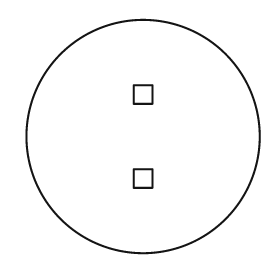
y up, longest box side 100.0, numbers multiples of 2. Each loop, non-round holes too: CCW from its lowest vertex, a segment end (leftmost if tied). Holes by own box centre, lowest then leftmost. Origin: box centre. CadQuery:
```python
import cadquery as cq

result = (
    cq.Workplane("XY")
    .moveTo(0.0, 0.0)
    .circle(50.0)
    .moveTo(-4.0, -22.0)
    .lineTo(4.0, -22.0)
    .lineTo(4.0, -14.0)
    .lineTo(-4.0, -14.0)
    .close()
    .moveTo(-4.0, 14.0)
    .lineTo(4.0, 14.0)
    .lineTo(4.0, 22.0)
    .lineTo(-4.0, 22.0)
    .close()
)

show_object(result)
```